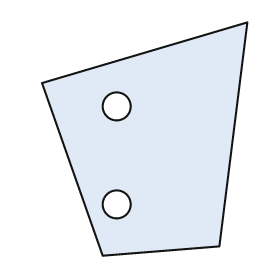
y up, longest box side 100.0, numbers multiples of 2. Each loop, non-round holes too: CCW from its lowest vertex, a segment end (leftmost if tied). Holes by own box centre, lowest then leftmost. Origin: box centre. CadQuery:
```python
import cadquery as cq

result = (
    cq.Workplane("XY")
    .moveTo(-18.0, -50.0)
    .lineTo(32.0, -46.0)
    .lineTo(44.0, 50.0)
    .lineTo(-44.0, 24.0)
    .close()
    .moveTo(-12.0, -28.0)
    .circle(6.0)
    .moveTo(-12.0, 14.0)
    .circle(6.0)
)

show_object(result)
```